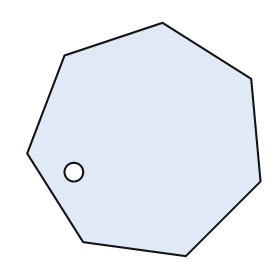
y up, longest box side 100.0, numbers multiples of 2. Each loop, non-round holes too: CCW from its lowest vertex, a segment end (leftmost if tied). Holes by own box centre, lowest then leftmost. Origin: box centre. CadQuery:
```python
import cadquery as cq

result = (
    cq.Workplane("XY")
    .moveTo(18.0, -50.0)
    .lineTo(50.0, -18.0)
    .lineTo(46.0, 26.0)
    .lineTo(8.0, 50.0)
    .lineTo(-34.0, 36.0)
    .lineTo(-50.0, -6.0)
    .lineTo(-26.0, -44.0)
    .close()
    .moveTo(-30.0, -14.0)
    .circle(4.0)
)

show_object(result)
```